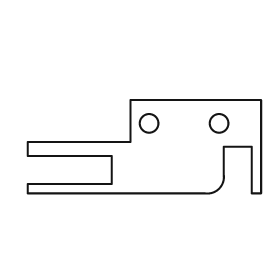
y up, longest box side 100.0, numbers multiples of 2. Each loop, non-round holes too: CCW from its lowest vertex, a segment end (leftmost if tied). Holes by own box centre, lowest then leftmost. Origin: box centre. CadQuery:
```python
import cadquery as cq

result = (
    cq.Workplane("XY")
    .moveTo(-50.0, -20.0)
    .lineTo(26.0, -20.0)
    .threePointArc((32.0, -18.0), (34.0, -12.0))
    .lineTo(34.0, 0.0)
    .lineTo(46.0, 0.0)
    .lineTo(46.0, -20.0)
    .lineTo(50.0, -20.0)
    .lineTo(50.0, 20.0)
    .lineTo(-6.0, 20.0)
    .lineTo(-6.0, 2.0)
    .lineTo(-50.0, 2.0)
    .lineTo(-50.0, -4.0)
    .lineTo(-14.0, -4.0)
    .lineTo(-14.0, -16.0)
    .lineTo(-50.0, -16.0)
    .close()
    .moveTo(2.0, 10.0)
    .circle(4.0)
    .moveTo(32.0, 10.0)
    .circle(4.0)
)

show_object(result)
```